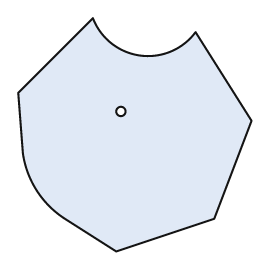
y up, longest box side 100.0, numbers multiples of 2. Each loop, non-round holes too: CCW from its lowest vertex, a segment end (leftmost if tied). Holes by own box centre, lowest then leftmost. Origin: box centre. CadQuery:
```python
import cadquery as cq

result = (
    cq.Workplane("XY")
    .moveTo(-8.0, -50.0)
    .lineTo(34.0, -36.0)
    .lineTo(50.0, 6.0)
    .lineTo(26.0, 44.0)
    .threePointArc((2.0, 34.0), (-18.0, 50.0))
    .lineTo(-50.0, 18.0)
    .lineTo(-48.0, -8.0)
    .threePointArc((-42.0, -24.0), (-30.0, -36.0))
    .close()
    .moveTo(-6.0, 10.0)
    .circle(2.0)
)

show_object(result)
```